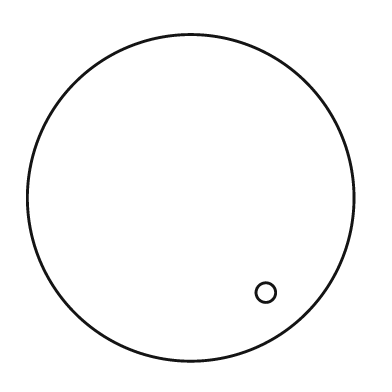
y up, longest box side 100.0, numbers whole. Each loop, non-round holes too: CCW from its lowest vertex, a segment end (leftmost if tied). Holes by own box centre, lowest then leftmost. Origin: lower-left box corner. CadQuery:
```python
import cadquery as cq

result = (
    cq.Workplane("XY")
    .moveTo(50.0, 50.0)
    .circle(50.0)
    .moveTo(73.0, 21.0)
    .circle(3.0)
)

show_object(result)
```